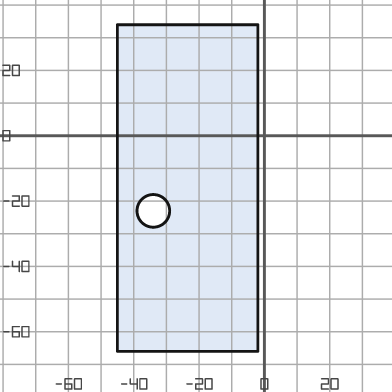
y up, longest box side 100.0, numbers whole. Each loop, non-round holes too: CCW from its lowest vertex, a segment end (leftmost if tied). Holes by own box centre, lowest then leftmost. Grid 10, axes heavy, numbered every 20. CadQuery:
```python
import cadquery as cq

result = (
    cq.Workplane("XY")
    .moveTo(-45.0, -66.0)
    .lineTo(-2.0, -66.0)
    .lineTo(-2.0, 34.0)
    .lineTo(-45.0, 34.0)
    .close()
    .moveTo(-34.0, -23.0)
    .circle(5.0)
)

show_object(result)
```